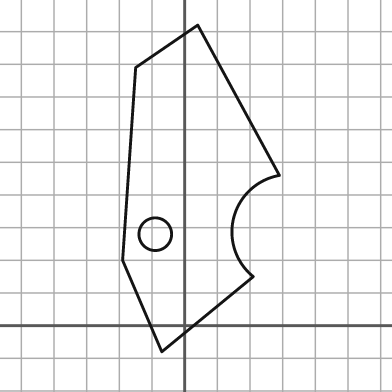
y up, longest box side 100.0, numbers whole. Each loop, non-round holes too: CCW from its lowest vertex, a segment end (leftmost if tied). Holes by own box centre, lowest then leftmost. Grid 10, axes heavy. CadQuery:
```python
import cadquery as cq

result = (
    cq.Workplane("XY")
    .moveTo(-7.0, -8.0)
    .lineTo(21.0, 15.0)
    .threePointArc((15.0, 33.0), (29.0, 46.0))
    .lineTo(4.0, 92.0)
    .lineTo(-15.0, 79.0)
    .lineTo(-19.0, 20.0)
    .close()
    .moveTo(-9.0, 28.0)
    .circle(5.0)
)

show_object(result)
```